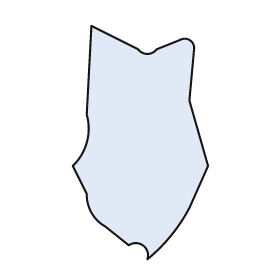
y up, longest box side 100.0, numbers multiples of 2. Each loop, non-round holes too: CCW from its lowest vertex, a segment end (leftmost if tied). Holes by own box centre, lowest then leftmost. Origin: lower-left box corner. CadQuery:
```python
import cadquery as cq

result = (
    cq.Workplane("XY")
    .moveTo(32.0, 0.0)
    .threePointArc((42.0, 10.0), (50.0, 22.0))
    .lineTo(58.0, 40.0)
    .lineTo(50.0, 68.0)
    .lineTo(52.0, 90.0)
    .threePointArc((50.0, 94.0), (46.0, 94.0))
    .lineTo(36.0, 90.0)
    .threePointArc((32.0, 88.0), (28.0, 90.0))
    .lineTo(8.0, 100.0)
    .lineTo(6.0, 62.0)
    .threePointArc((6.0, 50.0), (0.0, 40.0))
    .lineTo(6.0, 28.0)
    .threePointArc((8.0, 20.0), (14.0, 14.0))
    .lineTo(24.0, 6.0)
    .threePointArc((30.0, 6.0), (32.0, 0.0))
    .close()
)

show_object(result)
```